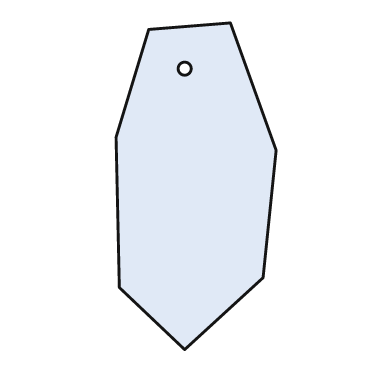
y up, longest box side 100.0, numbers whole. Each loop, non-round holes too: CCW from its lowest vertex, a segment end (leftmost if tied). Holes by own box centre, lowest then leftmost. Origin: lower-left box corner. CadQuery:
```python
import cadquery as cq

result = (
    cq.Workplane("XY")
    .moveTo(21.0, 0.0)
    .lineTo(45.0, 22.0)
    .lineTo(49.0, 61.0)
    .lineTo(35.0, 100.0)
    .lineTo(10.0, 98.0)
    .lineTo(0.0, 65.0)
    .lineTo(1.0, 19.0)
    .close()
    .moveTo(21.0, 86.0)
    .circle(2.0)
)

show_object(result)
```